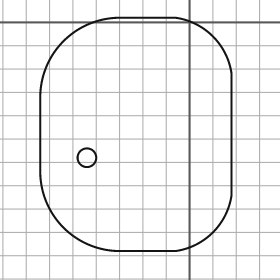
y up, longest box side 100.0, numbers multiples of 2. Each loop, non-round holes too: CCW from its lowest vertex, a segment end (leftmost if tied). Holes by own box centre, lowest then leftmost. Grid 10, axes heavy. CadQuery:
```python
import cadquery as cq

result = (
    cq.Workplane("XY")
    .moveTo(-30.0, -98.0)
    .lineTo(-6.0, -98.0)
    .threePointArc((10.0, -90.0), (18.0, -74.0))
    .lineTo(18.0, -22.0)
    .threePointArc((10.0, -6.0), (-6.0, 2.0))
    .lineTo(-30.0, 2.0)
    .threePointArc((-54.0, -8.0), (-64.0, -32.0))
    .lineTo(-64.0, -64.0)
    .threePointArc((-54.0, -88.0), (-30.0, -98.0))
    .close()
    .moveTo(-44.0, -58.0)
    .circle(4.0)
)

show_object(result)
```